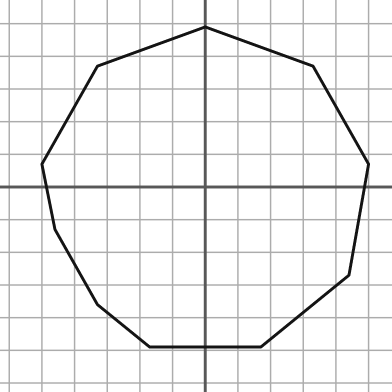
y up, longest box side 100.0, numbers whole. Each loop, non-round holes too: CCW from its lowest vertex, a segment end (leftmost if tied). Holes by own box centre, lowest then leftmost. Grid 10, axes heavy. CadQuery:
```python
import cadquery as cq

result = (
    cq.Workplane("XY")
    .moveTo(-17.0, -49.0)
    .lineTo(17.0, -49.0)
    .lineTo(44.0, -27.0)
    .lineTo(50.0, 7.0)
    .lineTo(33.0, 37.0)
    .lineTo(0.0, 49.0)
    .lineTo(-33.0, 37.0)
    .lineTo(-50.0, 7.0)
    .lineTo(-46.0, -13.0)
    .lineTo(-33.0, -36.0)
    .close()
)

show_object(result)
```